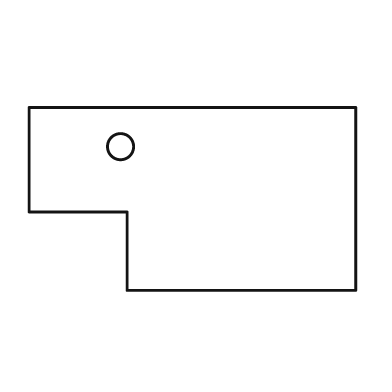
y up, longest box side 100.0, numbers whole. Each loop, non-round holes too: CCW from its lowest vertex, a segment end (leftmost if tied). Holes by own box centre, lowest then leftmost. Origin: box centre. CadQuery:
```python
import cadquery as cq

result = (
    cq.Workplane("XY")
    .moveTo(-20.0, -28.0)
    .lineTo(50.0, -28.0)
    .lineTo(50.0, 28.0)
    .lineTo(-50.0, 28.0)
    .lineTo(-50.0, -4.0)
    .lineTo(-20.0, -4.0)
    .close()
    .moveTo(-22.0, 16.0)
    .circle(4.0)
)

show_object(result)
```